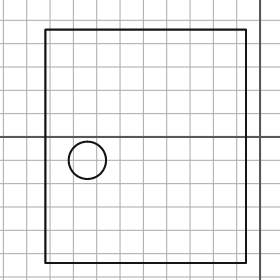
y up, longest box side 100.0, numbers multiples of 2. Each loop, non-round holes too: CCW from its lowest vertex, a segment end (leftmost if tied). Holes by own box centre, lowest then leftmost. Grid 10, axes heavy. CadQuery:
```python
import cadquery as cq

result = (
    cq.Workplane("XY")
    .moveTo(-92.0, -54.0)
    .lineTo(-6.0, -54.0)
    .lineTo(-6.0, 46.0)
    .lineTo(-92.0, 46.0)
    .close()
    .moveTo(-74.0, -10.0)
    .circle(8.0)
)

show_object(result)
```